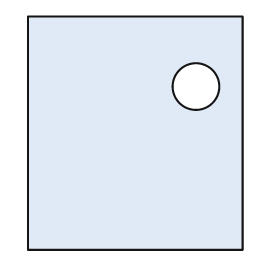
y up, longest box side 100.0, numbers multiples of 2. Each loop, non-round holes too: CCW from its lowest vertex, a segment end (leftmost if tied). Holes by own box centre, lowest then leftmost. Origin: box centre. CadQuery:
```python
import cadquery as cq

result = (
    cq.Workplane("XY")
    .moveTo(-46.0, -50.0)
    .lineTo(46.0, -50.0)
    .lineTo(46.0, 50.0)
    .lineTo(-46.0, 50.0)
    .close()
    .moveTo(26.0, 20.0)
    .circle(10.0)
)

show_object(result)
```